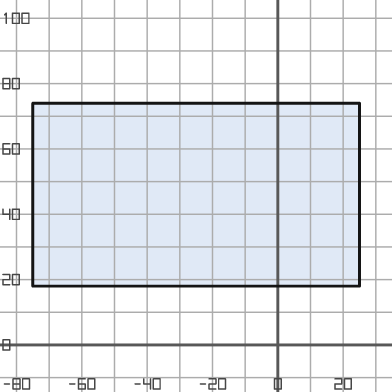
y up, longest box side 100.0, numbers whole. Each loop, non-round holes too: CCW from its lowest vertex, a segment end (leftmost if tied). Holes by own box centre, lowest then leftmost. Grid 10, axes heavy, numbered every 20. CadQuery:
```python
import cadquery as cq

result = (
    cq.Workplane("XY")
    .moveTo(-75.0, 18.0)
    .lineTo(25.0, 18.0)
    .lineTo(25.0, 74.0)
    .lineTo(-75.0, 74.0)
    .close()
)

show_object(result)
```